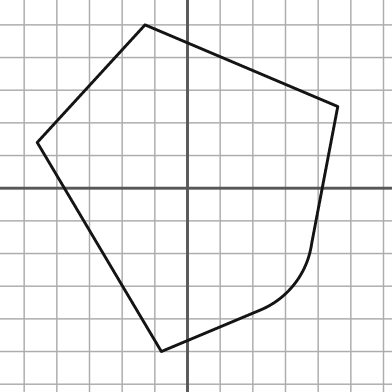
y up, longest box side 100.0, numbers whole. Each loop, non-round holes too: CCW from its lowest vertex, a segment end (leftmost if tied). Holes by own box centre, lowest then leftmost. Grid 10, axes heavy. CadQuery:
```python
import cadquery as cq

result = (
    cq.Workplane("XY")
    .moveTo(-8.0, -50.0)
    .lineTo(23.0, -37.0)
    .threePointArc((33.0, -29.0), (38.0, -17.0))
    .lineTo(46.0, 25.0)
    .lineTo(-13.0, 50.0)
    .lineTo(-46.0, 14.0)
    .close()
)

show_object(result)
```